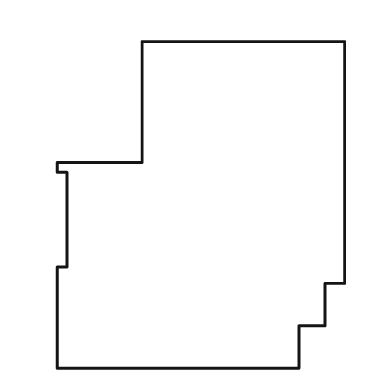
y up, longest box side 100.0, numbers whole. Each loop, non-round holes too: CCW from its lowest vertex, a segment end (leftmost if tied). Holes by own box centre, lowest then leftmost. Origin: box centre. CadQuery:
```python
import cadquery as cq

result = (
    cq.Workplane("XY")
    .moveTo(-44.0, -50.0)
    .lineTo(30.0, -50.0)
    .lineTo(30.0, -37.0)
    .lineTo(38.0, -37.0)
    .lineTo(38.0, -24.0)
    .lineTo(44.0, -24.0)
    .lineTo(44.0, 50.0)
    .lineTo(-18.0, 50.0)
    .lineTo(-18.0, 13.0)
    .lineTo(-44.0, 13.0)
    .lineTo(-44.0, 10.0)
    .lineTo(-41.0, 10.0)
    .lineTo(-41.0, -19.0)
    .lineTo(-44.0, -19.0)
    .close()
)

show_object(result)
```